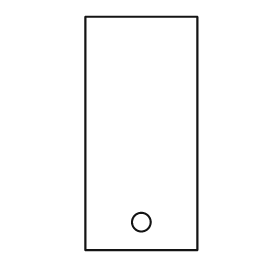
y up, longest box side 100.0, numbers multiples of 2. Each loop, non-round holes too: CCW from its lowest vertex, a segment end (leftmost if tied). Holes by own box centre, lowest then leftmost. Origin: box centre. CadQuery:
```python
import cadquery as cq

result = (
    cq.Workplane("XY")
    .moveTo(-24.0, -50.0)
    .lineTo(24.0, -50.0)
    .lineTo(24.0, 50.0)
    .lineTo(-24.0, 50.0)
    .close()
    .moveTo(0.0, -38.0)
    .circle(4.0)
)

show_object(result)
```